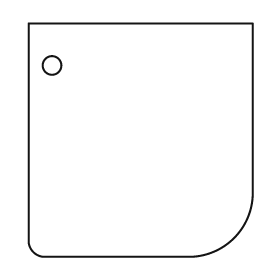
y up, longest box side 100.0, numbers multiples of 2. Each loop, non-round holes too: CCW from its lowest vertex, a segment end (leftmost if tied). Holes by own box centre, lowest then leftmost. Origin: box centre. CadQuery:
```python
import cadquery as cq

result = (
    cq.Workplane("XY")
    .moveTo(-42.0, -50.0)
    .lineTo(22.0, -50.0)
    .threePointArc((40.0, -42.0), (48.0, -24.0))
    .lineTo(48.0, 50.0)
    .lineTo(-48.0, 50.0)
    .lineTo(-48.0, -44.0)
    .threePointArc((-46.0, -48.0), (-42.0, -50.0))
    .close()
    .moveTo(-38.0, 32.0)
    .circle(4.0)
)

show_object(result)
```